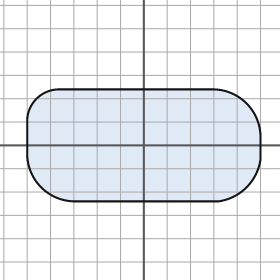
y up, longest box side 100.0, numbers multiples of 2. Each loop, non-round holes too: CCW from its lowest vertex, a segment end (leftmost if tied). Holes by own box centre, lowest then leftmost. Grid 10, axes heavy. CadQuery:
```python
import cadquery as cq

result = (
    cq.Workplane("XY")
    .moveTo(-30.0, -24.0)
    .lineTo(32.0, -24.0)
    .threePointArc((44.0, -18.0), (50.0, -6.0))
    .lineTo(50.0, 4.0)
    .threePointArc((44.0, 18.0), (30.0, 24.0))
    .lineTo(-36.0, 24.0)
    .threePointArc((-46.0, 20.0), (-50.0, 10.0))
    .lineTo(-50.0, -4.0)
    .threePointArc((-44.0, -18.0), (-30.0, -24.0))
    .close()
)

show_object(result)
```